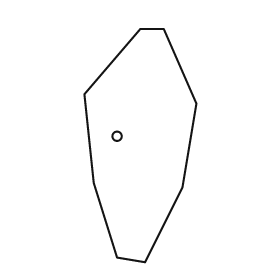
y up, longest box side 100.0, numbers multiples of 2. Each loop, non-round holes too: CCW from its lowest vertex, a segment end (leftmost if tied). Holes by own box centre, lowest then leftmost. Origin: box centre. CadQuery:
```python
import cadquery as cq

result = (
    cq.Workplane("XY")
    .moveTo(2.0, -50.0)
    .lineTo(18.0, -18.0)
    .lineTo(24.0, 18.0)
    .lineTo(10.0, 50.0)
    .lineTo(0.0, 50.0)
    .lineTo(-24.0, 22.0)
    .lineTo(-20.0, -16.0)
    .lineTo(-10.0, -48.0)
    .close()
    .moveTo(-10.0, 4.0)
    .circle(2.0)
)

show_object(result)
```